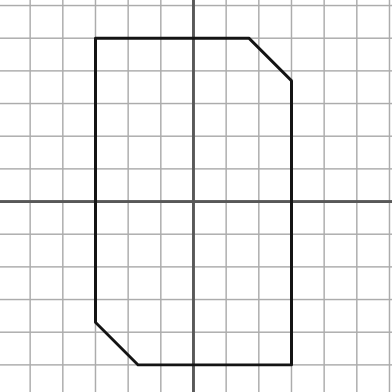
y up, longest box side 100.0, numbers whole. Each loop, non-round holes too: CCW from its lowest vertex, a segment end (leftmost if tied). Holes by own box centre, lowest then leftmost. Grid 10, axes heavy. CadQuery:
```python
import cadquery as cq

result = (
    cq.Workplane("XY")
    .moveTo(-17.0, -50.0)
    .lineTo(30.0, -50.0)
    .lineTo(30.0, 37.0)
    .lineTo(17.0, 50.0)
    .lineTo(-30.0, 50.0)
    .lineTo(-30.0, -37.0)
    .close()
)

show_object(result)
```